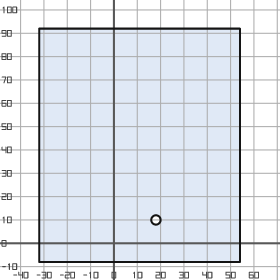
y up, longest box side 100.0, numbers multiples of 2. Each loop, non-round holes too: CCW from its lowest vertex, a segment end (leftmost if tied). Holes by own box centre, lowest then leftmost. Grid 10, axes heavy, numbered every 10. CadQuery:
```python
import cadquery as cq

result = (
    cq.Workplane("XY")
    .moveTo(-32.0, -8.0)
    .lineTo(54.0, -8.0)
    .lineTo(54.0, 92.0)
    .lineTo(-32.0, 92.0)
    .close()
    .moveTo(18.0, 10.0)
    .circle(2.0)
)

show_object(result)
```